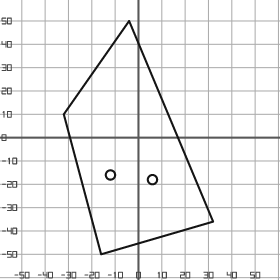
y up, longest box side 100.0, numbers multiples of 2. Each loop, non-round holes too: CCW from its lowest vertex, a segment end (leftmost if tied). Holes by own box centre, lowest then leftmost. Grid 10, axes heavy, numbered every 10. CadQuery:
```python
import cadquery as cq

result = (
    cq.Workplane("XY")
    .moveTo(-16.0, -50.0)
    .lineTo(32.0, -36.0)
    .lineTo(-4.0, 50.0)
    .lineTo(-32.0, 10.0)
    .close()
    .moveTo(6.0, -18.0)
    .circle(2.0)
    .moveTo(-12.0, -16.0)
    .circle(2.0)
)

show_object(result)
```